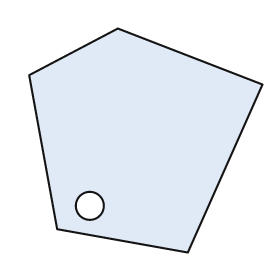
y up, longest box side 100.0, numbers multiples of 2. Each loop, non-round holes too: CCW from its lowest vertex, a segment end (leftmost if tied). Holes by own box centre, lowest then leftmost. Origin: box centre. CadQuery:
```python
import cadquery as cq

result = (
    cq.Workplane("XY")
    .moveTo(18.0, -48.0)
    .lineTo(50.0, 24.0)
    .lineTo(-12.0, 48.0)
    .lineTo(-50.0, 28.0)
    .lineTo(-38.0, -38.0)
    .close()
    .moveTo(-24.0, -28.0)
    .circle(6.0)
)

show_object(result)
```